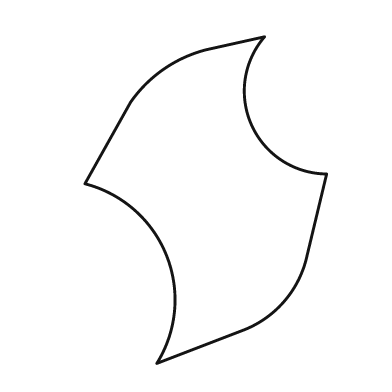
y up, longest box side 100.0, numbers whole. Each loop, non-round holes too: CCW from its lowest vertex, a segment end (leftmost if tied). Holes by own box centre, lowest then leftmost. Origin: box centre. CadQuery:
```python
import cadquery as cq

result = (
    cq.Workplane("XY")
    .moveTo(-15.0, -50.0)
    .lineTo(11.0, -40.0)
    .threePointArc((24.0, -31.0), (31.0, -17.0))
    .lineTo(37.0, 8.0)
    .threePointArc((14.0, 23.0), (18.0, 50.0))
    .lineTo(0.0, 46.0)
    .threePointArc((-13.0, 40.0), (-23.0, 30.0))
    .lineTo(-37.0, 5.0)
    .threePointArc((-12.0, -17.0), (-15.0, -50.0))
    .close()
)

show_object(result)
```